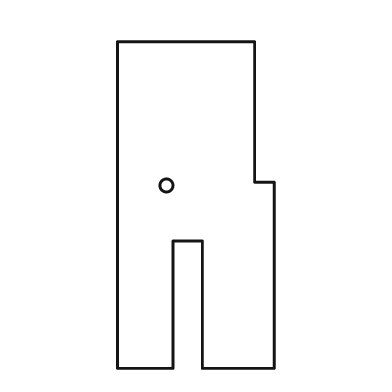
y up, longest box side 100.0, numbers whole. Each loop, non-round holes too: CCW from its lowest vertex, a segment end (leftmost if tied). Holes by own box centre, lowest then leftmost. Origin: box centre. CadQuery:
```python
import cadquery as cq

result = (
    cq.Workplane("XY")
    .moveTo(-24.0, -50.0)
    .lineTo(-7.0, -50.0)
    .lineTo(-7.0, -11.0)
    .lineTo(2.0, -11.0)
    .lineTo(2.0, -50.0)
    .lineTo(24.0, -50.0)
    .lineTo(24.0, 7.0)
    .lineTo(18.0, 7.0)
    .lineTo(18.0, 50.0)
    .lineTo(-24.0, 50.0)
    .close()
    .moveTo(-9.0, 6.0)
    .circle(2.0)
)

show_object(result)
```